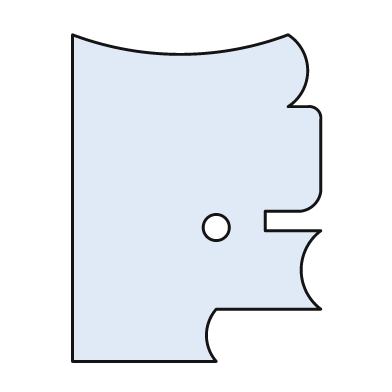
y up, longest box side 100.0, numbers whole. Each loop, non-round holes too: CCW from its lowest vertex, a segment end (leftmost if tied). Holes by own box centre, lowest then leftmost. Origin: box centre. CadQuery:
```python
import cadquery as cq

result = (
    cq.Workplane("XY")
    .moveTo(-38.0, -50.0)
    .lineTo(6.0, -50.0)
    .threePointArc((3.0, -42.0), (6.0, -34.0))
    .lineTo(38.0, -34.0)
    .threePointArc((32.0, -22.0), (38.0, -10.0))
    .lineTo(21.0, -10.0)
    .lineTo(21.0, -4.0)
    .lineTo(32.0, -4.0)
    .threePointArc((36.0, -2.0), (38.0, 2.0))
    .lineTo(38.0, 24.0)
    .threePointArc((37.0, 27.0), (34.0, 28.0))
    .lineTo(28.0, 28.0)
    .threePointArc((34.0, 39.0), (28.0, 50.0))
    .threePointArc((-5.0, 44.0), (-38.0, 50.0))
    .close()
    .moveTo(6.0, -9.0)
    .circle(4.0)
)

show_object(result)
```